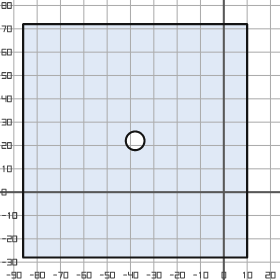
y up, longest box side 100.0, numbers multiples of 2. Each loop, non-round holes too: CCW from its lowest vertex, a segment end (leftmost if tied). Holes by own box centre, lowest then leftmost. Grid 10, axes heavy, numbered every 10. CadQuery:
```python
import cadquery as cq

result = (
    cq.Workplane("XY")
    .moveTo(-86.0, -28.0)
    .lineTo(10.0, -28.0)
    .lineTo(10.0, 72.0)
    .lineTo(-86.0, 72.0)
    .close()
    .moveTo(-38.0, 22.0)
    .circle(4.0)
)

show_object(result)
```